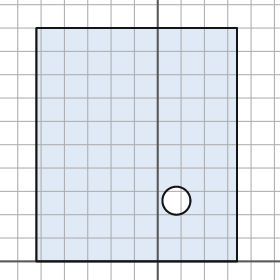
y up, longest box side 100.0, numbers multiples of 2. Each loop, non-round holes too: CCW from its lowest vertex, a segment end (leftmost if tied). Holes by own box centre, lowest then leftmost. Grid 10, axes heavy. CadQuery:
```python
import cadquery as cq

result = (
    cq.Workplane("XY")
    .moveTo(-52.0, 0.0)
    .lineTo(34.0, 0.0)
    .lineTo(34.0, 100.0)
    .lineTo(-52.0, 100.0)
    .close()
    .moveTo(8.0, 26.0)
    .circle(6.0)
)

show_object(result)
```